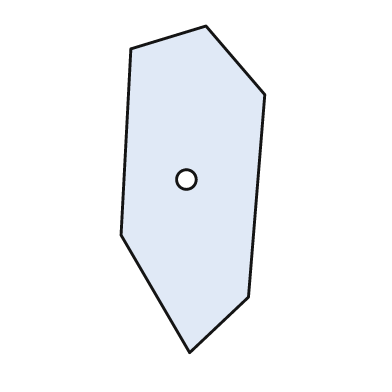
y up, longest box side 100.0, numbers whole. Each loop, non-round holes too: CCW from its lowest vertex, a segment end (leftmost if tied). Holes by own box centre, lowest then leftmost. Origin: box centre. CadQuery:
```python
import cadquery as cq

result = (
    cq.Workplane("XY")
    .moveTo(-1.0, -50.0)
    .lineTo(17.0, -33.0)
    .lineTo(22.0, 29.0)
    .lineTo(4.0, 50.0)
    .lineTo(-19.0, 43.0)
    .lineTo(-22.0, -14.0)
    .close()
    .moveTo(-2.0, 3.0)
    .circle(3.0)
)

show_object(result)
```